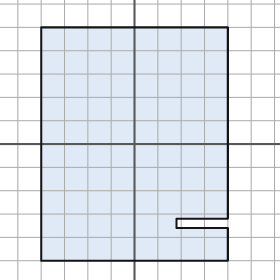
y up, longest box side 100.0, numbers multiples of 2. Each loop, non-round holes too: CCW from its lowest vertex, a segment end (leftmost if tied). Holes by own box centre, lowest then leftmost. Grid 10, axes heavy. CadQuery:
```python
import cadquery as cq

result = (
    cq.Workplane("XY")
    .moveTo(-40.0, -50.0)
    .lineTo(40.0, -50.0)
    .lineTo(40.0, -36.0)
    .lineTo(18.0, -36.0)
    .lineTo(18.0, -32.0)
    .lineTo(40.0, -32.0)
    .lineTo(40.0, 50.0)
    .lineTo(-40.0, 50.0)
    .close()
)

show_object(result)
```